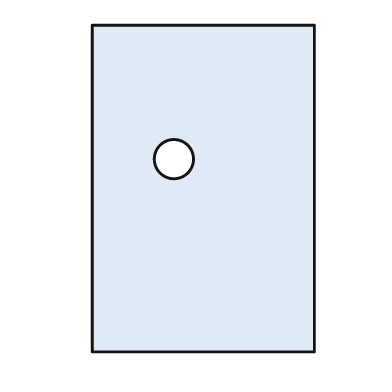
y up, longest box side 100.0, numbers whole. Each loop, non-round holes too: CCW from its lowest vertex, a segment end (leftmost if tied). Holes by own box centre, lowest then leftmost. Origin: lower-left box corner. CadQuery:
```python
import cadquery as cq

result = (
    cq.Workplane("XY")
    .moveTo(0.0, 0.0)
    .lineTo(68.0, 0.0)
    .lineTo(68.0, 100.0)
    .lineTo(0.0, 100.0)
    .close()
    .moveTo(25.0, 59.0)
    .circle(6.0)
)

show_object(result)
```